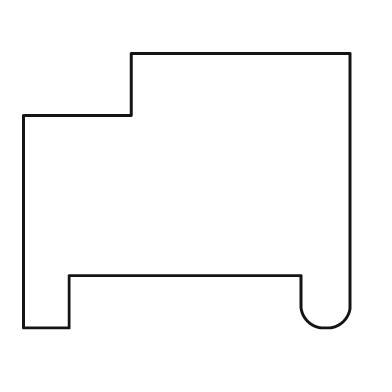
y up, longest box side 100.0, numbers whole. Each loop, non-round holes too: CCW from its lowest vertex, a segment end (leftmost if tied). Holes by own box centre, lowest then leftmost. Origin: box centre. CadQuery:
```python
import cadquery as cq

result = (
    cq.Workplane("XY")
    .moveTo(-50.0, -42.0)
    .lineTo(-36.0, -42.0)
    .lineTo(-36.0, -26.0)
    .lineTo(35.0, -26.0)
    .lineTo(35.0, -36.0)
    .threePointArc((37.0, -40.0), (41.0, -42.0))
    .lineTo(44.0, -42.0)
    .threePointArc((48.0, -40.0), (50.0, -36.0))
    .lineTo(50.0, 42.0)
    .lineTo(-17.0, 42.0)
    .lineTo(-17.0, 23.0)
    .lineTo(-50.0, 23.0)
    .close()
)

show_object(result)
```